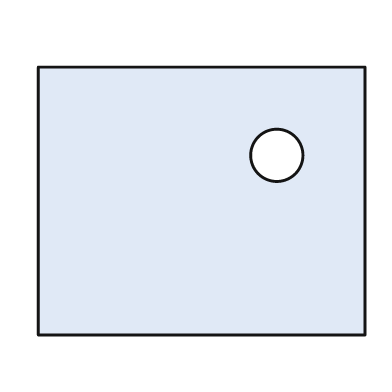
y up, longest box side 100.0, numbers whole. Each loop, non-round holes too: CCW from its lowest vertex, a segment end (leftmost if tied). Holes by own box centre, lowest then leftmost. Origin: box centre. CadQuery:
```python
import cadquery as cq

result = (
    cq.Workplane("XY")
    .moveTo(-50.0, -41.0)
    .lineTo(50.0, -41.0)
    .lineTo(50.0, 41.0)
    .lineTo(-50.0, 41.0)
    .close()
    .moveTo(23.0, 14.0)
    .circle(8.0)
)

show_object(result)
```